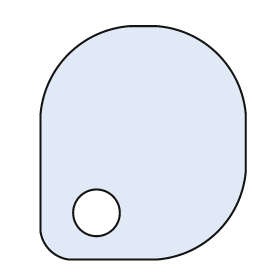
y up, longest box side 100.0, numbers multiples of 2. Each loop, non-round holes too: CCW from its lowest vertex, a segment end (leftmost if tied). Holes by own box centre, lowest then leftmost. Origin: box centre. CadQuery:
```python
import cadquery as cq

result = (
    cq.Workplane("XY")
    .moveTo(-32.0, -50.0)
    .lineTo(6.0, -50.0)
    .threePointArc((32.0, -38.0), (44.0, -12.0))
    .lineTo(44.0, 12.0)
    .threePointArc((32.0, 38.0), (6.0, 50.0))
    .lineTo(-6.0, 50.0)
    .threePointArc((-32.0, 38.0), (-44.0, 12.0))
    .lineTo(-44.0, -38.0)
    .threePointArc((-40.0, -46.0), (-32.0, -50.0))
    .close()
    .moveTo(-20.0, -30.0)
    .circle(10.0)
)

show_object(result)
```